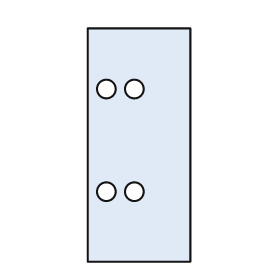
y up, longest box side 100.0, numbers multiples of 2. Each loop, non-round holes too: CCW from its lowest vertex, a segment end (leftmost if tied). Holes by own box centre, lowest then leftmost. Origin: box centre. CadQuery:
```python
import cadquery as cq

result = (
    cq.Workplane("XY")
    .moveTo(-22.0, -50.0)
    .lineTo(22.0, -50.0)
    .lineTo(22.0, 50.0)
    .lineTo(-22.0, 50.0)
    .close()
    .moveTo(-14.0, -20.0)
    .circle(4.0)
    .moveTo(-2.0, -20.0)
    .circle(4.0)
    .moveTo(-14.0, 24.0)
    .circle(4.0)
    .moveTo(-2.0, 24.0)
    .circle(4.0)
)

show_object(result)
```